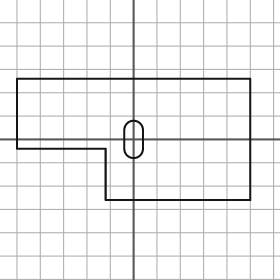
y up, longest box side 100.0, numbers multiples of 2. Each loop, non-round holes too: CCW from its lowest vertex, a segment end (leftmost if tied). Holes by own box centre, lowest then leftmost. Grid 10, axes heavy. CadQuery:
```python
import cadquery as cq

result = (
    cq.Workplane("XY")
    .moveTo(-12.0, -26.0)
    .lineTo(50.0, -26.0)
    .lineTo(50.0, 26.0)
    .lineTo(-50.0, 26.0)
    .lineTo(-50.0, -4.0)
    .lineTo(-12.0, -4.0)
    .close()
    .moveTo(-4.0, -4.0)
    .threePointArc((0.0, -8.0), (4.0, -4.0))
    .lineTo(4.0, 4.0)
    .threePointArc((0.0, 8.0), (-4.0, 4.0))
    .close()
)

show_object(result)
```